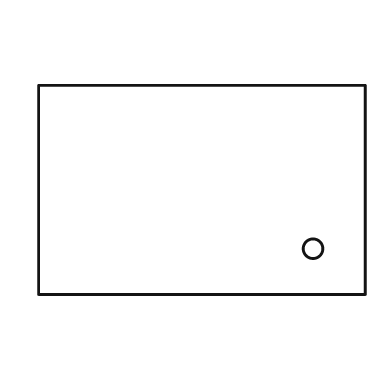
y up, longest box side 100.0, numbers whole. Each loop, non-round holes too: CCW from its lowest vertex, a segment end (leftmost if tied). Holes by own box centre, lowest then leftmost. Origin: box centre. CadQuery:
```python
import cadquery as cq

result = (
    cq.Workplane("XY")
    .moveTo(-50.0, -32.0)
    .lineTo(50.0, -32.0)
    .lineTo(50.0, 32.0)
    .lineTo(-50.0, 32.0)
    .close()
    .moveTo(34.0, -18.0)
    .circle(3.0)
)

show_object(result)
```